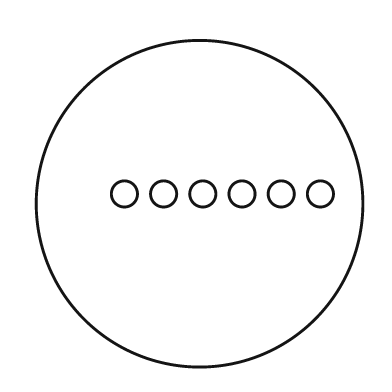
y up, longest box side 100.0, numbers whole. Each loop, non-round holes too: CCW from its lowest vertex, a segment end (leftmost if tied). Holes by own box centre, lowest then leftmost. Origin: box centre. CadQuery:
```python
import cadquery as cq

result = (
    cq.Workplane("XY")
    .moveTo(0.0, 0.0)
    .circle(50.0)
    .moveTo(-23.0, 3.0)
    .circle(4.0)
    .moveTo(-11.0, 3.0)
    .circle(4.0)
    .moveTo(1.0, 3.0)
    .circle(4.0)
    .moveTo(13.0, 3.0)
    .circle(4.0)
    .moveTo(25.0, 3.0)
    .circle(4.0)
    .moveTo(37.0, 3.0)
    .circle(4.0)
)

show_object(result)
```